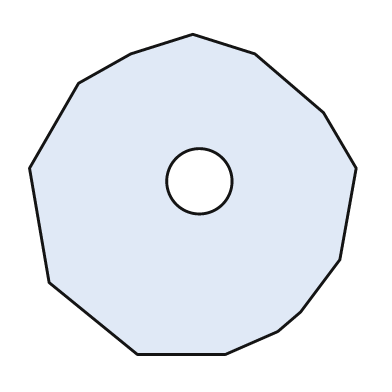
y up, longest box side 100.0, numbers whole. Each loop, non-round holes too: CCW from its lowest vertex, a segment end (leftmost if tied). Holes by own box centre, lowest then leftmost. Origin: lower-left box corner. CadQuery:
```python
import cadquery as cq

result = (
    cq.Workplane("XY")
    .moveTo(33.0, 0.0)
    .lineTo(60.0, 0.0)
    .lineTo(76.0, 7.0)
    .lineTo(83.0, 13.0)
    .lineTo(95.0, 29.0)
    .lineTo(100.0, 57.0)
    .lineTo(90.0, 74.0)
    .lineTo(69.0, 92.0)
    .lineTo(50.0, 98.0)
    .lineTo(31.0, 92.0)
    .lineTo(15.0, 83.0)
    .lineTo(0.0, 57.0)
    .lineTo(6.0, 22.0)
    .close()
    .moveTo(52.0, 53.0)
    .circle(10.0)
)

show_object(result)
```